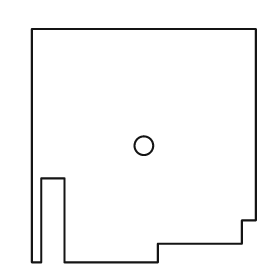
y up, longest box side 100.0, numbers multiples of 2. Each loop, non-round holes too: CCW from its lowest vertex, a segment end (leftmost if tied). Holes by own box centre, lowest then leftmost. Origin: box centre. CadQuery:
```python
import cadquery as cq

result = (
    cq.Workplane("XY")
    .moveTo(-48.0, -50.0)
    .lineTo(-44.0, -50.0)
    .lineTo(-44.0, -14.0)
    .lineTo(-34.0, -14.0)
    .lineTo(-34.0, -50.0)
    .lineTo(6.0, -50.0)
    .lineTo(6.0, -42.0)
    .lineTo(42.0, -42.0)
    .lineTo(42.0, -32.0)
    .lineTo(48.0, -32.0)
    .lineTo(48.0, 50.0)
    .lineTo(-48.0, 50.0)
    .close()
    .moveTo(0.0, 0.0)
    .circle(4.0)
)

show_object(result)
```